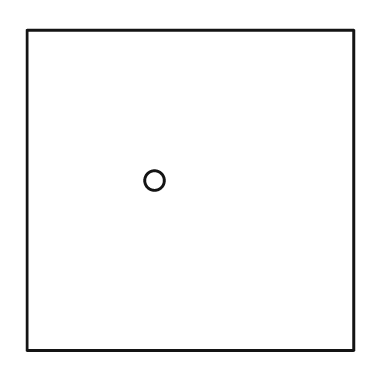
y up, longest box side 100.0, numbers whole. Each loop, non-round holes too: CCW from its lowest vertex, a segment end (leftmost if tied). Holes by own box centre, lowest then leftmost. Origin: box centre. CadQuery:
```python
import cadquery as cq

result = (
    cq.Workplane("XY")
    .moveTo(-50.0, -49.0)
    .lineTo(50.0, -49.0)
    .lineTo(50.0, 49.0)
    .lineTo(-50.0, 49.0)
    .close()
    .moveTo(-11.0, 3.0)
    .circle(3.0)
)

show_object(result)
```